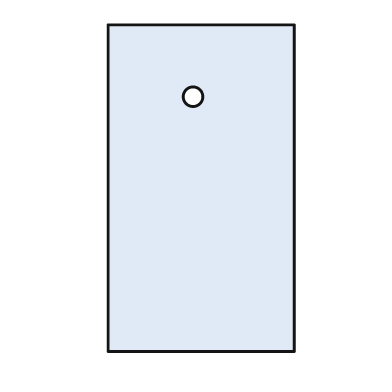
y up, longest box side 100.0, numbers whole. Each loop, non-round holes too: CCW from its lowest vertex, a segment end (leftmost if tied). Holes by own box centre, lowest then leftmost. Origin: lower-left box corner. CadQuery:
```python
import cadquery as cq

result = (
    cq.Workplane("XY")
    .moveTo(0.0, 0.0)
    .lineTo(57.0, 0.0)
    .lineTo(57.0, 100.0)
    .lineTo(0.0, 100.0)
    .close()
    .moveTo(26.0, 78.0)
    .circle(3.0)
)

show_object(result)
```